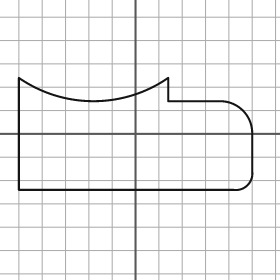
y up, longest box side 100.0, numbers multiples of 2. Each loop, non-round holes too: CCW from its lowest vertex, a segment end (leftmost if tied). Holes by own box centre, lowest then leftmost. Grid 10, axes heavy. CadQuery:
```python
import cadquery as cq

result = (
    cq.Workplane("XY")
    .moveTo(-50.0, -24.0)
    .lineTo(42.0, -24.0)
    .threePointArc((48.0, -22.0), (50.0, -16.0))
    .lineTo(50.0, 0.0)
    .threePointArc((46.0, 10.0), (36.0, 14.0))
    .lineTo(14.0, 14.0)
    .lineTo(14.0, 24.0)
    .threePointArc((-18.0, 14.0), (-50.0, 24.0))
    .close()
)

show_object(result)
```